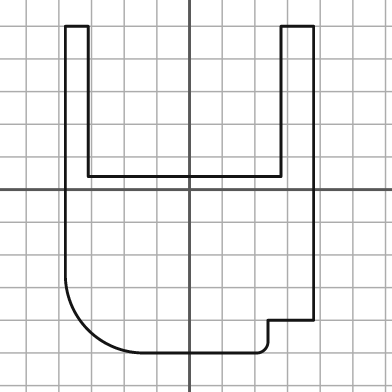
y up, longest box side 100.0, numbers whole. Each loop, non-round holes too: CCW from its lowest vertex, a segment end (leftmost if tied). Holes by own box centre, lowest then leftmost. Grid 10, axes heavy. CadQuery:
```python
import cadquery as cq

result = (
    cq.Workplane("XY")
    .moveTo(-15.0, -50.0)
    .lineTo(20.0, -50.0)
    .threePointArc((23.0, -49.0), (24.0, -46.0))
    .lineTo(24.0, -40.0)
    .lineTo(38.0, -40.0)
    .lineTo(38.0, 50.0)
    .lineTo(28.0, 50.0)
    .lineTo(28.0, 4.0)
    .lineTo(-31.0, 4.0)
    .lineTo(-31.0, 50.0)
    .lineTo(-38.0, 50.0)
    .lineTo(-38.0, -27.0)
    .threePointArc((-31.0, -43.0), (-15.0, -50.0))
    .close()
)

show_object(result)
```